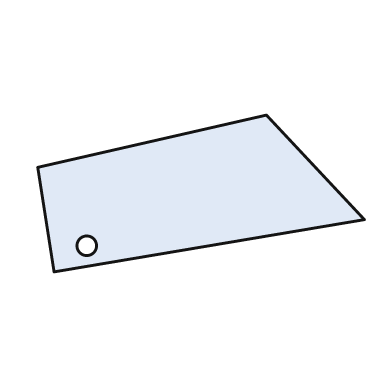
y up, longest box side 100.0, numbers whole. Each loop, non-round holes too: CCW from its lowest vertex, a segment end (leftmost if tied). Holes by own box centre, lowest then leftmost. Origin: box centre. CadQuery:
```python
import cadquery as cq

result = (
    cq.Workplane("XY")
    .moveTo(-45.0, -24.0)
    .lineTo(50.0, -8.0)
    .lineTo(20.0, 24.0)
    .lineTo(-50.0, 8.0)
    .close()
    .moveTo(-35.0, -16.0)
    .circle(3.0)
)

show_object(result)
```